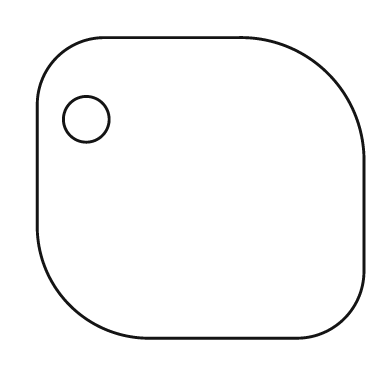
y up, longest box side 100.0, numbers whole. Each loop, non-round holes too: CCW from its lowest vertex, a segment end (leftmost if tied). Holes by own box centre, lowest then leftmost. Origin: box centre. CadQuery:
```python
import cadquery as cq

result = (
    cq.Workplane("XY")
    .moveTo(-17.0, -46.0)
    .lineTo(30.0, -46.0)
    .threePointArc((44.0, -40.0), (50.0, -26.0))
    .lineTo(50.0, 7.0)
    .threePointArc((39.0, 35.0), (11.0, 46.0))
    .lineTo(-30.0, 46.0)
    .threePointArc((-44.0, 40.0), (-50.0, 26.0))
    .lineTo(-50.0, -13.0)
    .threePointArc((-40.0, -36.0), (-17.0, -46.0))
    .close()
    .moveTo(-35.0, 21.0)
    .circle(7.0)
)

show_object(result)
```